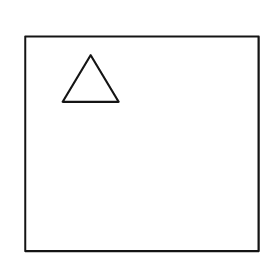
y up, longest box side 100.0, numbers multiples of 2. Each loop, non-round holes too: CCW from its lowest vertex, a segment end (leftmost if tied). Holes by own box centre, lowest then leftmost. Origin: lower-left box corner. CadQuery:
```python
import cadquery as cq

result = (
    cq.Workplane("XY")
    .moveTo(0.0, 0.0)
    .lineTo(100.0, 0.0)
    .lineTo(100.0, 92.0)
    .lineTo(0.0, 92.0)
    .close()
    .moveTo(16.0, 64.0)
    .lineTo(40.0, 64.0)
    .lineTo(28.0, 84.0)
    .close()
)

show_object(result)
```